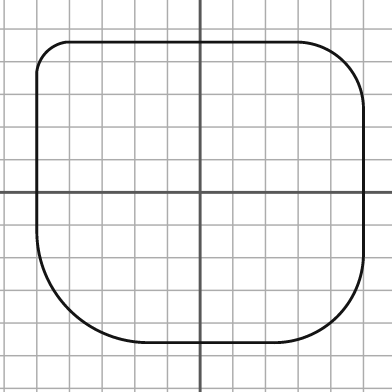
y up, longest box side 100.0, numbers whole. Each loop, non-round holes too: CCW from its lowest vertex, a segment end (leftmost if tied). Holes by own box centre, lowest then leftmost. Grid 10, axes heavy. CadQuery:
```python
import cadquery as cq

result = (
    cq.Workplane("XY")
    .moveTo(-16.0, -46.0)
    .lineTo(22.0, -46.0)
    .threePointArc((42.0, -38.0), (50.0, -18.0))
    .lineTo(50.0, 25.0)
    .threePointArc((44.0, 40.0), (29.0, 46.0))
    .lineTo(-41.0, 46.0)
    .threePointArc((-47.0, 43.0), (-50.0, 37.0))
    .lineTo(-50.0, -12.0)
    .threePointArc((-40.0, -36.0), (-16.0, -46.0))
    .close()
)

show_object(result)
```